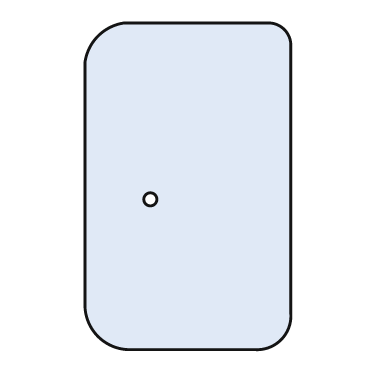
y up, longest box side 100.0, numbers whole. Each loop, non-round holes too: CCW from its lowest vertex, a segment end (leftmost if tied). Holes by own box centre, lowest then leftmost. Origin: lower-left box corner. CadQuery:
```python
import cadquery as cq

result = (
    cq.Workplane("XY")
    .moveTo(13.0, 0.0)
    .lineTo(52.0, 0.0)
    .threePointArc((60.0, 3.0), (63.0, 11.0))
    .lineTo(63.0, 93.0)
    .threePointArc((61.0, 98.0), (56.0, 100.0))
    .lineTo(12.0, 100.0)
    .threePointArc((4.0, 96.0), (0.0, 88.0))
    .lineTo(0.0, 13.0)
    .threePointArc((4.0, 4.0), (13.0, 0.0))
    .close()
    .moveTo(20.0, 46.0)
    .circle(2.0)
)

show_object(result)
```